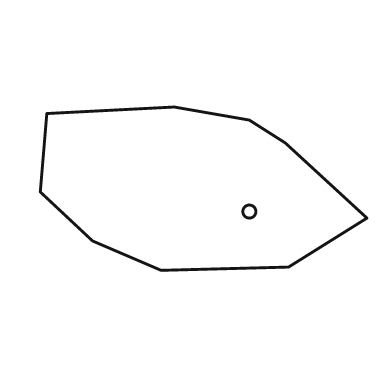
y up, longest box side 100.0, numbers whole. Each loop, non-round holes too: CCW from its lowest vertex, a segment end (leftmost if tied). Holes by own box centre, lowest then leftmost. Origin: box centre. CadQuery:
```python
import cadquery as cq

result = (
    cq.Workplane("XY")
    .moveTo(-13.0, -25.0)
    .lineTo(26.0, -24.0)
    .lineTo(50.0, -9.0)
    .lineTo(25.0, 14.0)
    .lineTo(14.0, 21.0)
    .lineTo(-9.0, 25.0)
    .lineTo(-48.0, 23.0)
    .lineTo(-50.0, -1.0)
    .lineTo(-34.0, -16.0)
    .close()
    .moveTo(14.0, -7.0)
    .circle(2.0)
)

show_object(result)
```